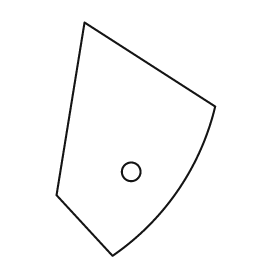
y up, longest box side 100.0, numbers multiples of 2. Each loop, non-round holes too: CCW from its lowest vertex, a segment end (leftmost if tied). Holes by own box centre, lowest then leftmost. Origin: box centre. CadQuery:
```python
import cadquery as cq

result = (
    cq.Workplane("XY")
    .moveTo(-10.0, -50.0)
    .threePointArc((18.0, -22.0), (34.0, 14.0))
    .lineTo(-22.0, 50.0)
    .lineTo(-34.0, -24.0)
    .close()
    .moveTo(-2.0, -14.0)
    .circle(4.0)
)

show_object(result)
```